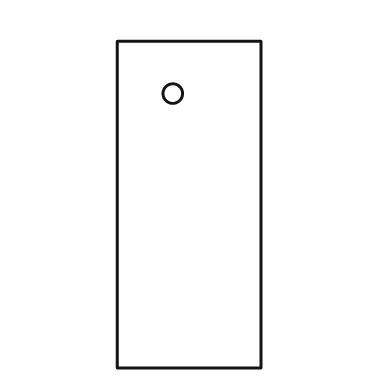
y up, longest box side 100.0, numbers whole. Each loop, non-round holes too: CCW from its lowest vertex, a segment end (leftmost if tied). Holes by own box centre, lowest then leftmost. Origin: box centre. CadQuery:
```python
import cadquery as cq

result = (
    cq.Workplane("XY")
    .moveTo(-22.0, -50.0)
    .lineTo(22.0, -50.0)
    .lineTo(22.0, 50.0)
    .lineTo(-22.0, 50.0)
    .close()
    .moveTo(-5.0, 34.0)
    .circle(3.0)
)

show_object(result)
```